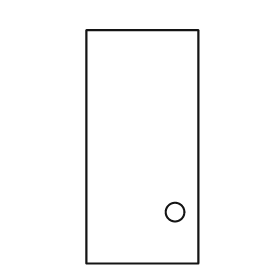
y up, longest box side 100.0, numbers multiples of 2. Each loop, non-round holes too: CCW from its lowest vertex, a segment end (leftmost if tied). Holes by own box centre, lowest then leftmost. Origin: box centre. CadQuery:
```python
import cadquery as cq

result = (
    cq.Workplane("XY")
    .moveTo(-24.0, -50.0)
    .lineTo(24.0, -50.0)
    .lineTo(24.0, 50.0)
    .lineTo(-24.0, 50.0)
    .close()
    .moveTo(14.0, -28.0)
    .circle(4.0)
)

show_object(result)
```